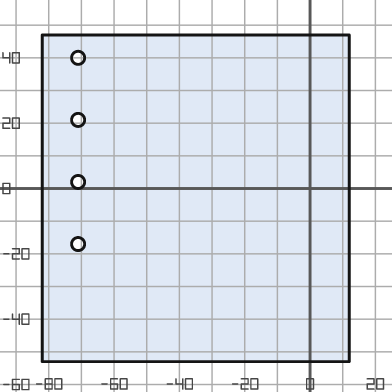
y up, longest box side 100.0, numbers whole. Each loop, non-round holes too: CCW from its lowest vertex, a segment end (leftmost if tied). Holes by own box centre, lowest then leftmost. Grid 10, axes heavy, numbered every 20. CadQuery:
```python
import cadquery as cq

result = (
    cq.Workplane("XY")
    .moveTo(-82.0, -53.0)
    .lineTo(12.0, -53.0)
    .lineTo(12.0, 47.0)
    .lineTo(-82.0, 47.0)
    .close()
    .moveTo(-71.0, -17.0)
    .circle(2.0)
    .moveTo(-71.0, 2.0)
    .circle(2.0)
    .moveTo(-71.0, 21.0)
    .circle(2.0)
    .moveTo(-71.0, 40.0)
    .circle(2.0)
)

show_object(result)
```